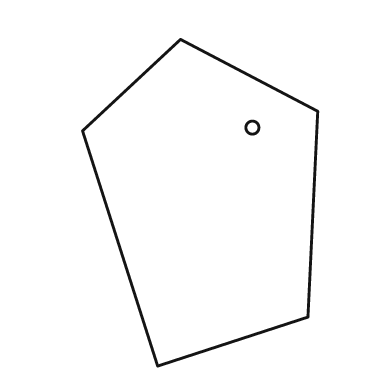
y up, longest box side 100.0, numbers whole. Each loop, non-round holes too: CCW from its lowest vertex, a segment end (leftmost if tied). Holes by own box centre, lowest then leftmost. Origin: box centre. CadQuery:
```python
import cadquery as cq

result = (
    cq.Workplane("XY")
    .moveTo(-13.0, -50.0)
    .lineTo(33.0, -35.0)
    .lineTo(36.0, 28.0)
    .lineTo(-6.0, 50.0)
    .lineTo(-36.0, 22.0)
    .close()
    .moveTo(16.0, 23.0)
    .circle(2.0)
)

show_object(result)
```